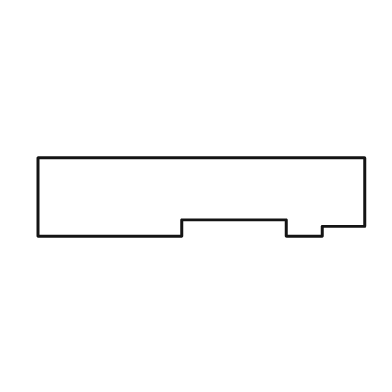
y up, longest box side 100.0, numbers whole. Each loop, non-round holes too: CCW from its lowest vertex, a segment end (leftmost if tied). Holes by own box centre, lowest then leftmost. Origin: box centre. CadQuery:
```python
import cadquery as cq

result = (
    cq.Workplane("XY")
    .moveTo(-50.0, -12.0)
    .lineTo(-6.0, -12.0)
    .lineTo(-6.0, -7.0)
    .lineTo(26.0, -7.0)
    .lineTo(26.0, -12.0)
    .lineTo(37.0, -12.0)
    .lineTo(37.0, -9.0)
    .lineTo(50.0, -9.0)
    .lineTo(50.0, 12.0)
    .lineTo(-50.0, 12.0)
    .close()
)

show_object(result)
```